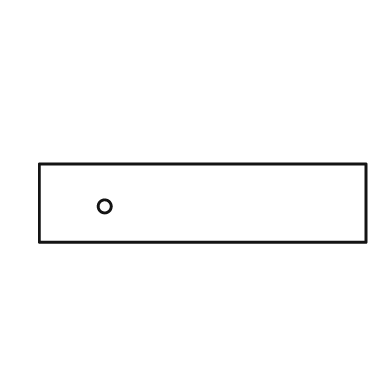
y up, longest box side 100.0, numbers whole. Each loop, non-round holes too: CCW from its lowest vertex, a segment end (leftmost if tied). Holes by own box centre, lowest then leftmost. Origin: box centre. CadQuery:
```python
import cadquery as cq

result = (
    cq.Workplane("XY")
    .moveTo(-50.0, -12.0)
    .lineTo(50.0, -12.0)
    .lineTo(50.0, 12.0)
    .lineTo(-50.0, 12.0)
    .close()
    .moveTo(-30.0, -1.0)
    .circle(2.0)
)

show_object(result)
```